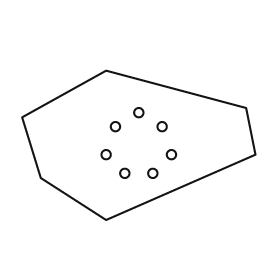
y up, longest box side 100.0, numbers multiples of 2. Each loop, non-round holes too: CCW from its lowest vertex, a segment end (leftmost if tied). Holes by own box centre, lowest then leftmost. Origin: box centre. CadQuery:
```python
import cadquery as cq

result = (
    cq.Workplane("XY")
    .moveTo(-14.0, -32.0)
    .lineTo(50.0, -4.0)
    .lineTo(46.0, 16.0)
    .lineTo(-14.0, 32.0)
    .lineTo(-50.0, 12.0)
    .lineTo(-42.0, -14.0)
    .close()
    .moveTo(-6.0, -12.0)
    .circle(2.0)
    .moveTo(6.0, -12.0)
    .circle(2.0)
    .moveTo(-14.0, -4.0)
    .circle(2.0)
    .moveTo(14.0, -4.0)
    .circle(2.0)
    .moveTo(-10.0, 8.0)
    .circle(2.0)
    .moveTo(10.0, 8.0)
    .circle(2.0)
    .moveTo(0.0, 14.0)
    .circle(2.0)
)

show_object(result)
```